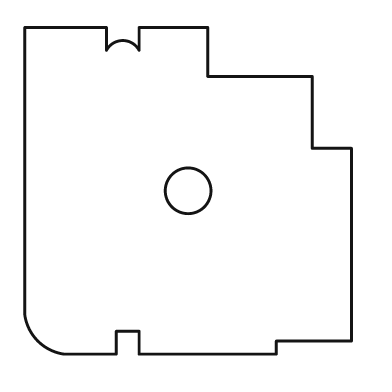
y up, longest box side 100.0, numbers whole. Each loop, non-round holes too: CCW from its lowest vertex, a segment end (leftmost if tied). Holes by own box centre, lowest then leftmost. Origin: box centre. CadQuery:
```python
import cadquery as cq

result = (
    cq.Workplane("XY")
    .moveTo(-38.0, -50.0)
    .lineTo(-22.0, -50.0)
    .lineTo(-22.0, -43.0)
    .lineTo(-15.0, -43.0)
    .lineTo(-15.0, -50.0)
    .lineTo(27.0, -50.0)
    .lineTo(27.0, -46.0)
    .lineTo(50.0, -46.0)
    .lineTo(50.0, 13.0)
    .lineTo(38.0, 13.0)
    .lineTo(38.0, 35.0)
    .lineTo(6.0, 35.0)
    .lineTo(6.0, 50.0)
    .lineTo(-15.0, 50.0)
    .lineTo(-15.0, 43.0)
    .threePointArc((-20.0, 46.0), (-25.0, 43.0))
    .lineTo(-25.0, 50.0)
    .lineTo(-50.0, 50.0)
    .lineTo(-50.0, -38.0)
    .threePointArc((-46.0, -46.0), (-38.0, -50.0))
    .close()
    .moveTo(0.0, 0.0)
    .circle(7.0)
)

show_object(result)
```